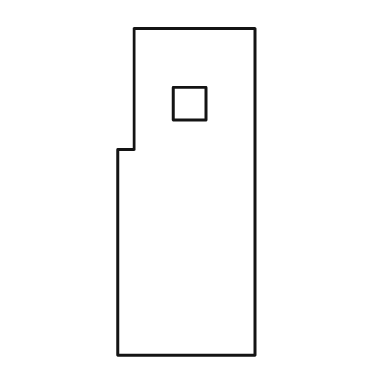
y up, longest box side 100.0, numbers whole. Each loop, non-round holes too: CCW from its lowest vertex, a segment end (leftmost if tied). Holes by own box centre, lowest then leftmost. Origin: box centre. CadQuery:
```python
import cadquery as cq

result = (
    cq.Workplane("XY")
    .moveTo(-21.0, -50.0)
    .lineTo(21.0, -50.0)
    .lineTo(21.0, 50.0)
    .lineTo(-16.0, 50.0)
    .lineTo(-16.0, 13.0)
    .lineTo(-21.0, 13.0)
    .close()
    .moveTo(-4.0, 22.0)
    .lineTo(6.0, 22.0)
    .lineTo(6.0, 32.0)
    .lineTo(-4.0, 32.0)
    .close()
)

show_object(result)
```